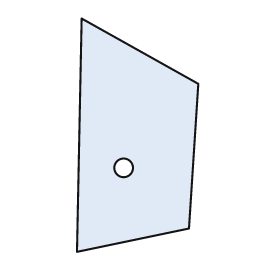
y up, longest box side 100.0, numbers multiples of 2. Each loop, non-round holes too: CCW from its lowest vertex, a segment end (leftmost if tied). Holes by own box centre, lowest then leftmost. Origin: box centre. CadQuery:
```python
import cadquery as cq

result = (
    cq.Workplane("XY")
    .moveTo(-26.0, -50.0)
    .lineTo(22.0, -40.0)
    .lineTo(26.0, 22.0)
    .lineTo(-24.0, 50.0)
    .close()
    .moveTo(-6.0, -14.0)
    .circle(4.0)
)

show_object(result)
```